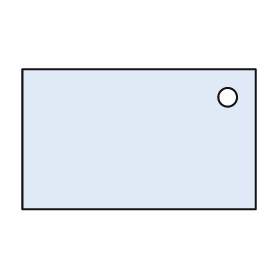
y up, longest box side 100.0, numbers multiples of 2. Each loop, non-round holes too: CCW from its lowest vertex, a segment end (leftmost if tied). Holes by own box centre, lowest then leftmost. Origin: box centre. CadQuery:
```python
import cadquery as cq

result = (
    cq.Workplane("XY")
    .moveTo(-50.0, -30.0)
    .lineTo(50.0, -30.0)
    .lineTo(50.0, 30.0)
    .lineTo(-50.0, 30.0)
    .close()
    .moveTo(38.0, 18.0)
    .circle(4.0)
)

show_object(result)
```